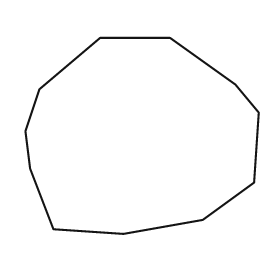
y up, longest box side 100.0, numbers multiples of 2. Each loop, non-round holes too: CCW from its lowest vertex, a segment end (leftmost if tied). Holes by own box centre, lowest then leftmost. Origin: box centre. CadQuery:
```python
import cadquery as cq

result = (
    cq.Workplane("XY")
    .moveTo(-8.0, -42.0)
    .lineTo(26.0, -36.0)
    .lineTo(48.0, -20.0)
    .lineTo(50.0, 10.0)
    .lineTo(40.0, 22.0)
    .lineTo(12.0, 42.0)
    .lineTo(-18.0, 42.0)
    .lineTo(-44.0, 20.0)
    .lineTo(-50.0, 2.0)
    .lineTo(-48.0, -14.0)
    .lineTo(-38.0, -40.0)
    .close()
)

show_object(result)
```